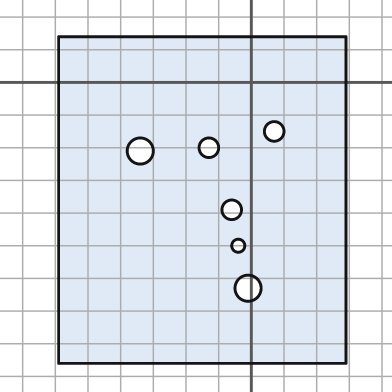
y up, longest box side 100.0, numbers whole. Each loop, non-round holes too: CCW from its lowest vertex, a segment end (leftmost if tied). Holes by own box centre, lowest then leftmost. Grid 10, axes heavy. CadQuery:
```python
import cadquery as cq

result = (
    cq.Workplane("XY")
    .moveTo(-59.0, -86.0)
    .lineTo(29.0, -86.0)
    .lineTo(29.0, 14.0)
    .lineTo(-59.0, 14.0)
    .close()
    .moveTo(-1.0, -63.0)
    .circle(4.0)
    .moveTo(-4.0, -50.0)
    .circle(2.0)
    .moveTo(-6.0, -39.0)
    .circle(3.0)
    .moveTo(-34.0, -21.0)
    .circle(4.0)
    .moveTo(-13.0, -20.0)
    .circle(3.0)
    .moveTo(7.0, -15.0)
    .circle(3.0)
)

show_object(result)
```